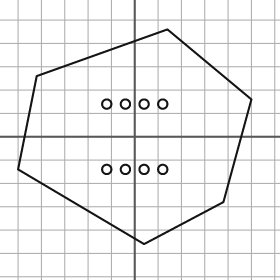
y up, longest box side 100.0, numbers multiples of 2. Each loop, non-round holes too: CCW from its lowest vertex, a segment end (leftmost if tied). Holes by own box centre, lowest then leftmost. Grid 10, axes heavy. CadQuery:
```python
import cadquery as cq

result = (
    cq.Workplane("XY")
    .moveTo(4.0, -46.0)
    .lineTo(38.0, -28.0)
    .lineTo(50.0, 16.0)
    .lineTo(14.0, 46.0)
    .lineTo(-42.0, 26.0)
    .lineTo(-50.0, -14.0)
    .close()
    .moveTo(-12.0, -14.0)
    .circle(2.0)
    .moveTo(-4.0, -14.0)
    .circle(2.0)
    .moveTo(4.0, -14.0)
    .circle(2.0)
    .moveTo(12.0, -14.0)
    .circle(2.0)
    .moveTo(-12.0, 14.0)
    .circle(2.0)
    .moveTo(-4.0, 14.0)
    .circle(2.0)
    .moveTo(4.0, 14.0)
    .circle(2.0)
    .moveTo(12.0, 14.0)
    .circle(2.0)
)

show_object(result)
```